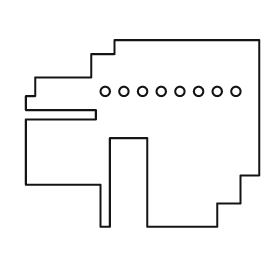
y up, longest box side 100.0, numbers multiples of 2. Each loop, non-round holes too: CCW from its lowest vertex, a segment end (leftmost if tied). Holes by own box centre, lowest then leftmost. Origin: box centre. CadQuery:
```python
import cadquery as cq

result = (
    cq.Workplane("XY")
    .moveTo(-18.0, -40.0)
    .lineTo(-14.0, -40.0)
    .lineTo(-14.0, -2.0)
    .lineTo(2.0, -2.0)
    .lineTo(2.0, -40.0)
    .lineTo(32.0, -40.0)
    .lineTo(32.0, -30.0)
    .lineTo(42.0, -30.0)
    .lineTo(42.0, -18.0)
    .lineTo(50.0, -18.0)
    .lineTo(50.0, 40.0)
    .lineTo(-12.0, 40.0)
    .lineTo(-12.0, 34.0)
    .lineTo(-22.0, 34.0)
    .lineTo(-22.0, 24.0)
    .lineTo(-46.0, 24.0)
    .lineTo(-46.0, 16.0)
    .lineTo(-50.0, 16.0)
    .lineTo(-50.0, 10.0)
    .lineTo(-20.0, 10.0)
    .lineTo(-20.0, 6.0)
    .lineTo(-50.0, 6.0)
    .lineTo(-50.0, -22.0)
    .lineTo(-18.0, -22.0)
    .close()
    .moveTo(-16.0, 18.0)
    .circle(2.0)
    .moveTo(-8.0, 18.0)
    .circle(2.0)
    .moveTo(0.0, 18.0)
    .circle(2.0)
    .moveTo(8.0, 18.0)
    .circle(2.0)
    .moveTo(16.0, 18.0)
    .circle(2.0)
    .moveTo(24.0, 18.0)
    .circle(2.0)
    .moveTo(32.0, 18.0)
    .circle(2.0)
    .moveTo(40.0, 18.0)
    .circle(2.0)
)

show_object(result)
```